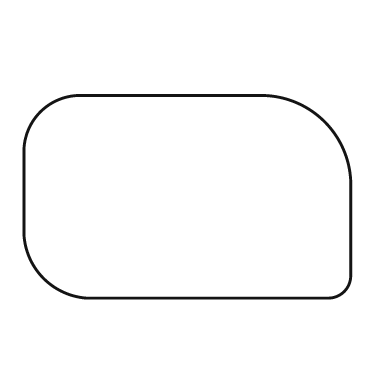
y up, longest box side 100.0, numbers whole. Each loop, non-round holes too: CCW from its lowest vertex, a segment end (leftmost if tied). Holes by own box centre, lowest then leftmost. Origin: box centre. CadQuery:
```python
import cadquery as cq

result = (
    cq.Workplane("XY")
    .moveTo(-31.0, -31.0)
    .lineTo(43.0, -31.0)
    .threePointArc((48.0, -29.0), (50.0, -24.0))
    .lineTo(50.0, 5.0)
    .threePointArc((42.0, 23.0), (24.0, 31.0))
    .lineTo(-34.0, 31.0)
    .threePointArc((-45.0, 26.0), (-50.0, 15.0))
    .lineTo(-50.0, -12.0)
    .threePointArc((-44.0, -25.0), (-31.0, -31.0))
    .close()
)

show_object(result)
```